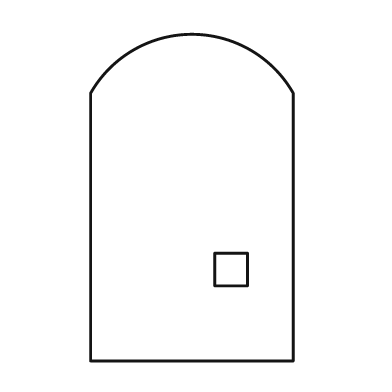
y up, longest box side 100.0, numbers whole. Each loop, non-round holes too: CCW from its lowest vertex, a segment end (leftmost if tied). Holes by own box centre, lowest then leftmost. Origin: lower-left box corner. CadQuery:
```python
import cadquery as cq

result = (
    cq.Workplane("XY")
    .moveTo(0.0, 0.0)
    .lineTo(62.0, 0.0)
    .lineTo(62.0, 82.0)
    .threePointArc((31.0, 100.0), (0.0, 82.0))
    .close()
    .moveTo(38.0, 23.0)
    .lineTo(48.0, 23.0)
    .lineTo(48.0, 33.0)
    .lineTo(38.0, 33.0)
    .close()
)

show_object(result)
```